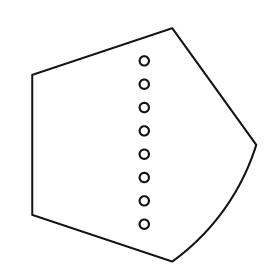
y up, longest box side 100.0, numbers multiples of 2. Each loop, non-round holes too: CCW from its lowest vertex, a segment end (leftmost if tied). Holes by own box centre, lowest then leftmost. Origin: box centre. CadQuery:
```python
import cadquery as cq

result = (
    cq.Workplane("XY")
    .moveTo(12.0, -50.0)
    .threePointArc((34.0, -28.0), (48.0, 0.0))
    .lineTo(12.0, 50.0)
    .lineTo(-48.0, 30.0)
    .lineTo(-48.0, -30.0)
    .close()
    .moveTo(0.0, -34.0)
    .circle(2.0)
    .moveTo(0.0, -24.0)
    .circle(2.0)
    .moveTo(0.0, -14.0)
    .circle(2.0)
    .moveTo(0.0, -4.0)
    .circle(2.0)
    .moveTo(0.0, 6.0)
    .circle(2.0)
    .moveTo(0.0, 16.0)
    .circle(2.0)
    .moveTo(0.0, 26.0)
    .circle(2.0)
    .moveTo(0.0, 36.0)
    .circle(2.0)
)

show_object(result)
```